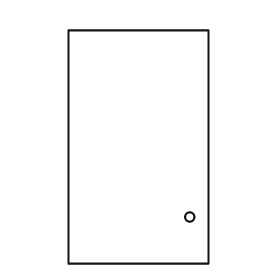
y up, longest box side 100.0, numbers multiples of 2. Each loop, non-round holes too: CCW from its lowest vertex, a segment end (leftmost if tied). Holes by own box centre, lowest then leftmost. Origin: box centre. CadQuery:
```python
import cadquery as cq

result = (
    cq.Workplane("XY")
    .moveTo(-30.0, -50.0)
    .lineTo(30.0, -50.0)
    .lineTo(30.0, 50.0)
    .lineTo(-30.0, 50.0)
    .close()
    .moveTo(22.0, -30.0)
    .circle(2.0)
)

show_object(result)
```